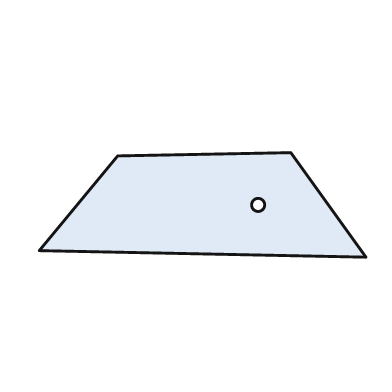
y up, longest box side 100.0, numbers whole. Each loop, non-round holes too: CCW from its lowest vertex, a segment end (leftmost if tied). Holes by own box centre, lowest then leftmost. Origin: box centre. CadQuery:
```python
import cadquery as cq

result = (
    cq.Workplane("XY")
    .moveTo(50.0, -16.0)
    .lineTo(27.0, 16.0)
    .lineTo(-26.0, 15.0)
    .lineTo(-50.0, -14.0)
    .close()
    .moveTo(17.0, 0.0)
    .circle(2.0)
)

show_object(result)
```